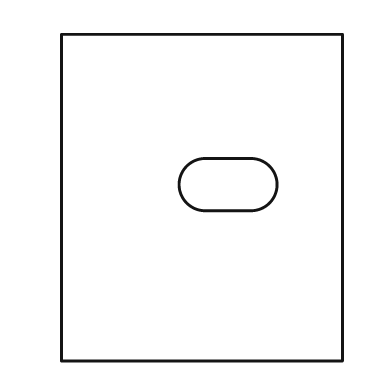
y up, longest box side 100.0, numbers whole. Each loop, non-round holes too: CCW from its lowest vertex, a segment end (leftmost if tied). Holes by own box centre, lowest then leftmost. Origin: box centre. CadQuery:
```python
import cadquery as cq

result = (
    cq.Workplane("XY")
    .moveTo(-43.0, -50.0)
    .lineTo(43.0, -50.0)
    .lineTo(43.0, 50.0)
    .lineTo(-43.0, 50.0)
    .close()
    .moveTo(1.0, -4.0)
    .lineTo(15.0, -4.0)
    .threePointArc((23.0, 4.0), (15.0, 12.0))
    .lineTo(1.0, 12.0)
    .threePointArc((-7.0, 4.0), (1.0, -4.0))
    .close()
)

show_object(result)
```